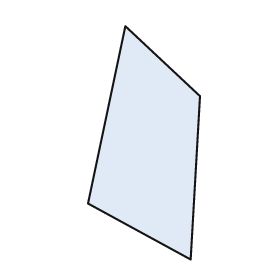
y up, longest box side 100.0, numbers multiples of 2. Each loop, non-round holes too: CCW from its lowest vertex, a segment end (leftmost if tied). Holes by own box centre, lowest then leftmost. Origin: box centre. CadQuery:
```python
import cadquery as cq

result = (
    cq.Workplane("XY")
    .moveTo(20.0, -50.0)
    .lineTo(24.0, 20.0)
    .lineTo(-8.0, 50.0)
    .lineTo(-24.0, -26.0)
    .close()
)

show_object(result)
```